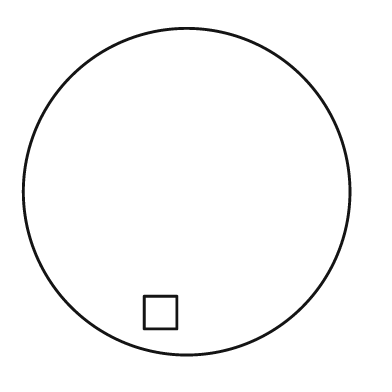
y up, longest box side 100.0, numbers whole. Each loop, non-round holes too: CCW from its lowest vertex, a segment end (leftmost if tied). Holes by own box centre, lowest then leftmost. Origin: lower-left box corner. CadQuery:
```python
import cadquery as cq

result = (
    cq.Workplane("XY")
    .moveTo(50.0, 50.0)
    .circle(50.0)
    .moveTo(37.0, 8.0)
    .lineTo(47.0, 8.0)
    .lineTo(47.0, 18.0)
    .lineTo(37.0, 18.0)
    .close()
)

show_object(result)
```